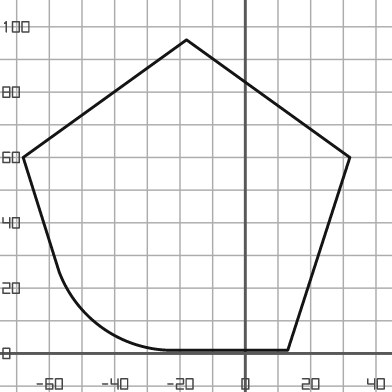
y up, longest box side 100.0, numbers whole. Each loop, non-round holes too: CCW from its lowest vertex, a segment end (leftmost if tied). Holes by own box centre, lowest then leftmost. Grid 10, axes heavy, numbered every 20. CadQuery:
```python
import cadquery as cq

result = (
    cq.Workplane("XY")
    .moveTo(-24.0, 1.0)
    .lineTo(13.0, 1.0)
    .lineTo(32.0, 60.0)
    .lineTo(-18.0, 96.0)
    .lineTo(-68.0, 60.0)
    .lineTo(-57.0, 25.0)
    .threePointArc((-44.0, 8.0), (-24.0, 1.0))
    .close()
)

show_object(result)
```